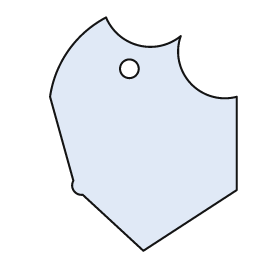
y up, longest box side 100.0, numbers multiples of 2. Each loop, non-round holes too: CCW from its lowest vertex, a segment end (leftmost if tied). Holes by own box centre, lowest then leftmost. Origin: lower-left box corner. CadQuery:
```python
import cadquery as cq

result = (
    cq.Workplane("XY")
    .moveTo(40.0, 0.0)
    .lineTo(80.0, 26.0)
    .lineTo(80.0, 66.0)
    .threePointArc((60.0, 72.0), (56.0, 92.0))
    .threePointArc((38.0, 88.0), (24.0, 100.0))
    .threePointArc((8.0, 86.0), (0.0, 66.0))
    .lineTo(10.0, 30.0)
    .threePointArc((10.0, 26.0), (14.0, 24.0))
    .close()
    .moveTo(34.0, 78.0)
    .circle(4.0)
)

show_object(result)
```